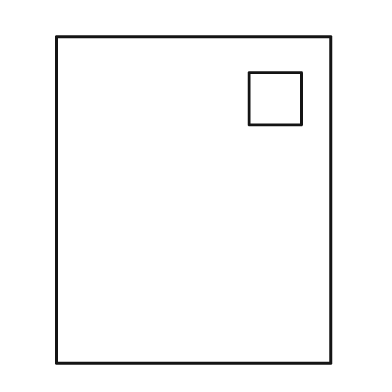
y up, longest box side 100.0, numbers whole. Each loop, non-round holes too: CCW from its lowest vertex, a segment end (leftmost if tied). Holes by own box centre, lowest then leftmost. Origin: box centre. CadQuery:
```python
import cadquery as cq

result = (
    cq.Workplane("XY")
    .moveTo(-42.0, -50.0)
    .lineTo(42.0, -50.0)
    .lineTo(42.0, 50.0)
    .lineTo(-42.0, 50.0)
    .close()
    .moveTo(17.0, 23.0)
    .lineTo(33.0, 23.0)
    .lineTo(33.0, 39.0)
    .lineTo(17.0, 39.0)
    .close()
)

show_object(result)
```